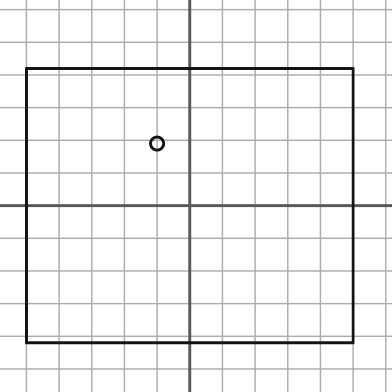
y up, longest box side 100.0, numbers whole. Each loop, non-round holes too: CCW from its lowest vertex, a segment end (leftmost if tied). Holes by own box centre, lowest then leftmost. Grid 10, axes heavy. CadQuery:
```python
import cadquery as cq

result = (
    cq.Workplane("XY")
    .moveTo(-50.0, -42.0)
    .lineTo(50.0, -42.0)
    .lineTo(50.0, 42.0)
    .lineTo(-50.0, 42.0)
    .close()
    .moveTo(-10.0, 19.0)
    .circle(2.0)
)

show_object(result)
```